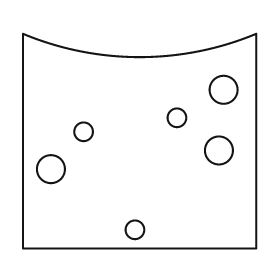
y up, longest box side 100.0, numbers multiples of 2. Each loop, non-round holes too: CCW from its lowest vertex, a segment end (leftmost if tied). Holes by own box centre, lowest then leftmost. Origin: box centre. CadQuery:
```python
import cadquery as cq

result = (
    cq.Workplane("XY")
    .moveTo(-50.0, -46.0)
    .lineTo(50.0, -46.0)
    .lineTo(50.0, 46.0)
    .threePointArc((0.0, 36.0), (-50.0, 46.0))
    .close()
    .moveTo(-2.0, -38.0)
    .circle(4.0)
    .moveTo(-38.0, -12.0)
    .circle(6.0)
    .moveTo(34.0, -4.0)
    .circle(6.0)
    .moveTo(-24.0, 4.0)
    .circle(4.0)
    .moveTo(16.0, 10.0)
    .circle(4.0)
    .moveTo(36.0, 22.0)
    .circle(6.0)
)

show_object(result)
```